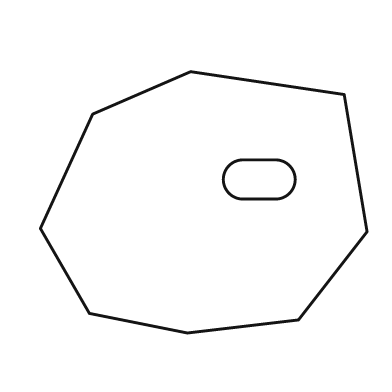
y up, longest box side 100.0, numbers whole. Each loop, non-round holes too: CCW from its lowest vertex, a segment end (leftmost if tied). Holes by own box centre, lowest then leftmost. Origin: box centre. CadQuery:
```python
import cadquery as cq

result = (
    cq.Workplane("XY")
    .moveTo(-5.0, -40.0)
    .lineTo(29.0, -36.0)
    .lineTo(50.0, -9.0)
    .lineTo(43.0, 33.0)
    .lineTo(-4.0, 40.0)
    .lineTo(-34.0, 27.0)
    .lineTo(-50.0, -8.0)
    .lineTo(-35.0, -34.0)
    .close()
    .moveTo(12.0, 1.0)
    .lineTo(22.0, 1.0)
    .threePointArc((28.0, 7.0), (22.0, 13.0))
    .lineTo(12.0, 13.0)
    .threePointArc((6.0, 7.0), (12.0, 1.0))
    .close()
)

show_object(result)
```